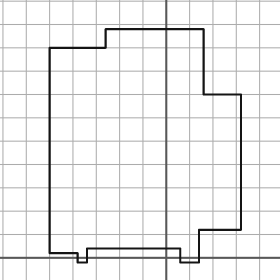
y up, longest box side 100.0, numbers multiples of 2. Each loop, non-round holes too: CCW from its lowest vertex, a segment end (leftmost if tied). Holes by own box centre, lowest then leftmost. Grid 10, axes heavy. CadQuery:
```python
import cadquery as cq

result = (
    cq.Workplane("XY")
    .moveTo(-38.0, -2.0)
    .lineTo(-34.0, -2.0)
    .lineTo(-34.0, 4.0)
    .lineTo(6.0, 4.0)
    .lineTo(6.0, -2.0)
    .lineTo(14.0, -2.0)
    .lineTo(14.0, 12.0)
    .lineTo(32.0, 12.0)
    .lineTo(32.0, 70.0)
    .lineTo(16.0, 70.0)
    .lineTo(16.0, 98.0)
    .lineTo(-26.0, 98.0)
    .lineTo(-26.0, 90.0)
    .lineTo(-50.0, 90.0)
    .lineTo(-50.0, 2.0)
    .lineTo(-38.0, 2.0)
    .close()
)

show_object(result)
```